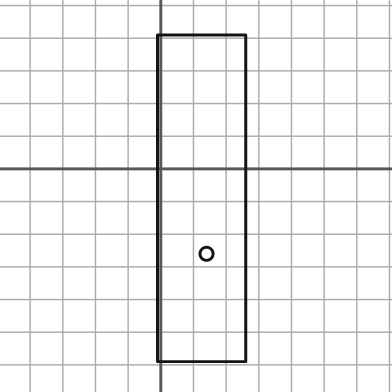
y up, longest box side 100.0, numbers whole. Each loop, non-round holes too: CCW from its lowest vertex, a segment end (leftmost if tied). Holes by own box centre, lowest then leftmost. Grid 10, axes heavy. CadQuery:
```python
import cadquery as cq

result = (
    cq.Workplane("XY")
    .moveTo(-1.0, -59.0)
    .lineTo(26.0, -59.0)
    .lineTo(26.0, 41.0)
    .lineTo(-1.0, 41.0)
    .close()
    .moveTo(14.0, -26.0)
    .circle(2.0)
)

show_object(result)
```